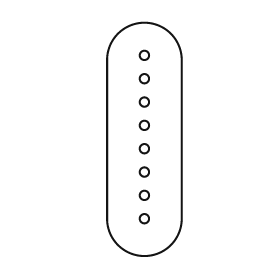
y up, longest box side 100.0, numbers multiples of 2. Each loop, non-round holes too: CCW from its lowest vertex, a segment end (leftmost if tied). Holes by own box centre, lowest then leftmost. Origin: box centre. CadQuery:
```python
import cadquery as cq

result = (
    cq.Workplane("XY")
    .moveTo(-16.0, -34.0)
    .threePointArc((0.0, -50.0), (16.0, -34.0))
    .lineTo(16.0, 34.0)
    .threePointArc((0.0, 50.0), (-16.0, 34.0))
    .close()
    .moveTo(0.0, -34.0)
    .circle(2.0)
    .moveTo(0.0, -24.0)
    .circle(2.0)
    .moveTo(0.0, -14.0)
    .circle(2.0)
    .moveTo(0.0, -4.0)
    .circle(2.0)
    .moveTo(0.0, 6.0)
    .circle(2.0)
    .moveTo(0.0, 16.0)
    .circle(2.0)
    .moveTo(0.0, 26.0)
    .circle(2.0)
    .moveTo(0.0, 36.0)
    .circle(2.0)
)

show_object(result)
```